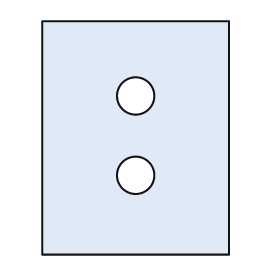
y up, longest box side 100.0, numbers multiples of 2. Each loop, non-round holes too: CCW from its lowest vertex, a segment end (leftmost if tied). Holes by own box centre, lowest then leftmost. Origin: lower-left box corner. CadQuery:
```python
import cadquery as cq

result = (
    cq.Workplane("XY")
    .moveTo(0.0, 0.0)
    .lineTo(80.0, 0.0)
    .lineTo(80.0, 100.0)
    .lineTo(0.0, 100.0)
    .close()
    .moveTo(40.0, 34.0)
    .circle(8.0)
    .moveTo(40.0, 68.0)
    .circle(8.0)
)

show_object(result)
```